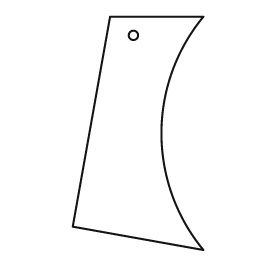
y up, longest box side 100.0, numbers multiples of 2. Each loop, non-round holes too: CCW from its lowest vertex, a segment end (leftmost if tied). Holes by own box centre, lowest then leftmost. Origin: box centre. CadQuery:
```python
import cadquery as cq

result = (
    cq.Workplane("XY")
    .moveTo(28.0, -50.0)
    .threePointArc((10.0, 0.0), (28.0, 50.0))
    .lineTo(-12.0, 50.0)
    .lineTo(-28.0, -40.0)
    .close()
    .moveTo(-2.0, 42.0)
    .circle(2.0)
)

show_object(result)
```